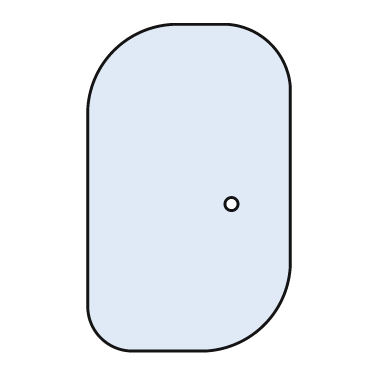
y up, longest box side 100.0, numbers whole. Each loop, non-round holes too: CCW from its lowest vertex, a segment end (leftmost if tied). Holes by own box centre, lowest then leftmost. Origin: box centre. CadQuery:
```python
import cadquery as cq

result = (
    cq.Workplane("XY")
    .moveTo(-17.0, -50.0)
    .lineTo(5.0, -50.0)
    .threePointArc((23.0, -42.0), (31.0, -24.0))
    .lineTo(31.0, 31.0)
    .threePointArc((25.0, 44.0), (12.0, 50.0))
    .lineTo(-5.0, 50.0)
    .threePointArc((-23.0, 42.0), (-31.0, 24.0))
    .lineTo(-31.0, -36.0)
    .threePointArc((-27.0, -46.0), (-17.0, -50.0))
    .close()
    .moveTo(13.0, -5.0)
    .circle(2.0)
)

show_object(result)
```